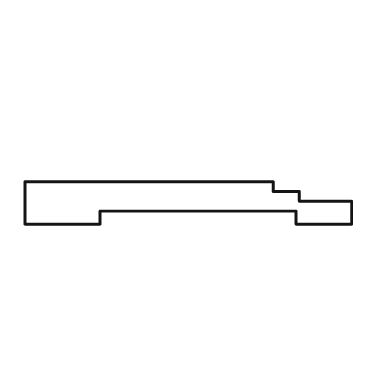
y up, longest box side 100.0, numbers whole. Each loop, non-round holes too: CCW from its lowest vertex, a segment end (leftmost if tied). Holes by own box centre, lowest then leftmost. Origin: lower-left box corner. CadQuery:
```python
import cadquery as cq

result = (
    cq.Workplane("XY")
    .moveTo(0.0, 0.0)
    .lineTo(23.0, 0.0)
    .lineTo(23.0, 4.0)
    .lineTo(83.0, 4.0)
    .lineTo(83.0, 0.0)
    .lineTo(100.0, 0.0)
    .lineTo(100.0, 7.0)
    .lineTo(84.0, 7.0)
    .lineTo(84.0, 10.0)
    .lineTo(76.0, 10.0)
    .lineTo(76.0, 13.0)
    .lineTo(0.0, 13.0)
    .close()
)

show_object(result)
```